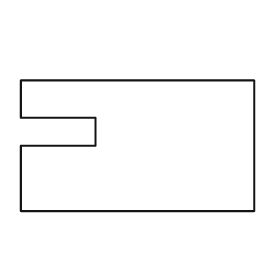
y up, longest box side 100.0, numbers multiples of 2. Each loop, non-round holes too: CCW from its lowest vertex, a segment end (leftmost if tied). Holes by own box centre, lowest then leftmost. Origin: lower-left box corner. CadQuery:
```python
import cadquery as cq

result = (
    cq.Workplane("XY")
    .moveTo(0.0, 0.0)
    .lineTo(100.0, 0.0)
    .lineTo(100.0, 56.0)
    .lineTo(0.0, 56.0)
    .lineTo(0.0, 40.0)
    .lineTo(32.0, 40.0)
    .lineTo(32.0, 28.0)
    .lineTo(0.0, 28.0)
    .close()
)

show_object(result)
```